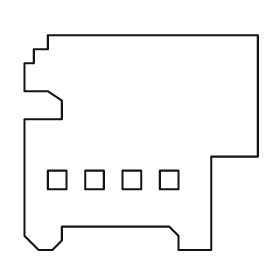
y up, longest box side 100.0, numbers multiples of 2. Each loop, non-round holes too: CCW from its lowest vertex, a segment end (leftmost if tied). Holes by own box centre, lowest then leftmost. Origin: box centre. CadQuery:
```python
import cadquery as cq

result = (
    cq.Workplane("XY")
    .moveTo(-44.0, -46.0)
    .lineTo(-38.0, -46.0)
    .lineTo(-34.0, -42.0)
    .lineTo(-34.0, -36.0)
    .lineTo(12.0, -36.0)
    .lineTo(16.0, -40.0)
    .lineTo(16.0, -46.0)
    .lineTo(30.0, -46.0)
    .lineTo(30.0, -6.0)
    .lineTo(50.0, -6.0)
    .lineTo(50.0, 46.0)
    .lineTo(-40.0, 46.0)
    .lineTo(-40.0, 40.0)
    .lineTo(-46.0, 40.0)
    .lineTo(-46.0, 34.0)
    .lineTo(-50.0, 34.0)
    .lineTo(-50.0, 22.0)
    .lineTo(-40.0, 22.0)
    .lineTo(-34.0, 18.0)
    .lineTo(-34.0, 10.0)
    .lineTo(-50.0, 10.0)
    .lineTo(-50.0, -40.0)
    .close()
    .moveTo(-40.0, -20.0)
    .lineTo(-32.0, -20.0)
    .lineTo(-32.0, -12.0)
    .lineTo(-40.0, -12.0)
    .close()
    .moveTo(-24.0, -20.0)
    .lineTo(-16.0, -20.0)
    .lineTo(-16.0, -12.0)
    .lineTo(-24.0, -12.0)
    .close()
    .moveTo(-8.0, -20.0)
    .lineTo(0.0, -20.0)
    .lineTo(0.0, -12.0)
    .lineTo(-8.0, -12.0)
    .close()
    .moveTo(8.0, -20.0)
    .lineTo(16.0, -20.0)
    .lineTo(16.0, -12.0)
    .lineTo(8.0, -12.0)
    .close()
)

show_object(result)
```